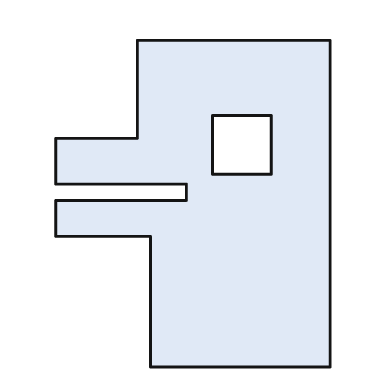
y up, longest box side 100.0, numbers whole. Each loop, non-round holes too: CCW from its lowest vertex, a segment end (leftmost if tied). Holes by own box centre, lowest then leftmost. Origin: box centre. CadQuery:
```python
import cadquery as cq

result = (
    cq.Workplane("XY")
    .moveTo(-13.0, -50.0)
    .lineTo(42.0, -50.0)
    .lineTo(42.0, 50.0)
    .lineTo(-17.0, 50.0)
    .lineTo(-17.0, 20.0)
    .lineTo(-42.0, 20.0)
    .lineTo(-42.0, 6.0)
    .lineTo(-2.0, 6.0)
    .lineTo(-2.0, 1.0)
    .lineTo(-42.0, 1.0)
    .lineTo(-42.0, -10.0)
    .lineTo(-13.0, -10.0)
    .close()
    .moveTo(6.0, 9.0)
    .lineTo(24.0, 9.0)
    .lineTo(24.0, 27.0)
    .lineTo(6.0, 27.0)
    .close()
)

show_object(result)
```